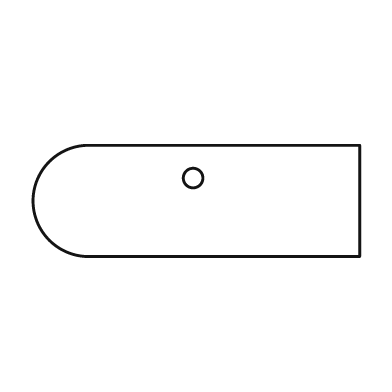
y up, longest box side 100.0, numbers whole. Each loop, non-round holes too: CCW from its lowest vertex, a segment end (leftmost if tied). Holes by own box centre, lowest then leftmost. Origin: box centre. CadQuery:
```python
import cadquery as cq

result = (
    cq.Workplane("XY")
    .moveTo(-34.0, -17.0)
    .lineTo(50.0, -17.0)
    .lineTo(50.0, 17.0)
    .lineTo(-34.0, 17.0)
    .threePointArc((-50.0, 0.0), (-34.0, -17.0))
    .close()
    .moveTo(-1.0, 7.0)
    .circle(3.0)
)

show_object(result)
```